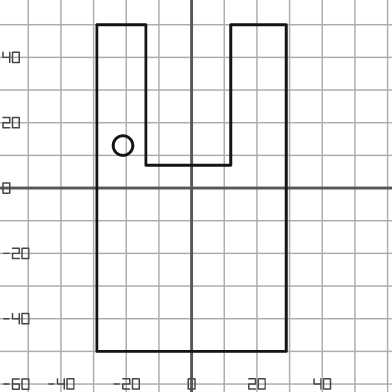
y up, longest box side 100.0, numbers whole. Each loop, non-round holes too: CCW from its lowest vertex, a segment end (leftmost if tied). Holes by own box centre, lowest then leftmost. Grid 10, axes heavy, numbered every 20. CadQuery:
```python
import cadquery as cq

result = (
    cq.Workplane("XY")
    .moveTo(-29.0, -50.0)
    .lineTo(29.0, -50.0)
    .lineTo(29.0, 50.0)
    .lineTo(12.0, 50.0)
    .lineTo(12.0, 7.0)
    .lineTo(-14.0, 7.0)
    .lineTo(-14.0, 50.0)
    .lineTo(-29.0, 50.0)
    .close()
    .moveTo(-21.0, 13.0)
    .circle(3.0)
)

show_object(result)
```